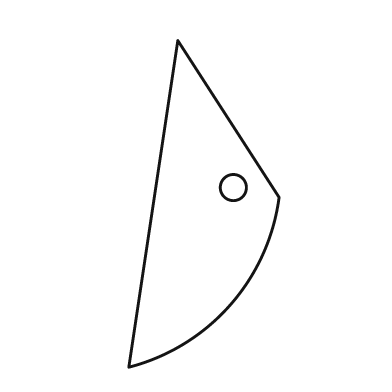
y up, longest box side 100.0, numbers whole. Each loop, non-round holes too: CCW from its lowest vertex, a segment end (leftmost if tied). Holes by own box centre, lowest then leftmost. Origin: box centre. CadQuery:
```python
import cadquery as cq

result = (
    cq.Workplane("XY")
    .moveTo(-23.0, -50.0)
    .threePointArc((8.0, -31.0), (23.0, 2.0))
    .lineTo(-8.0, 50.0)
    .close()
    .moveTo(9.0, 5.0)
    .circle(4.0)
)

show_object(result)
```